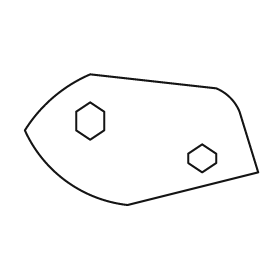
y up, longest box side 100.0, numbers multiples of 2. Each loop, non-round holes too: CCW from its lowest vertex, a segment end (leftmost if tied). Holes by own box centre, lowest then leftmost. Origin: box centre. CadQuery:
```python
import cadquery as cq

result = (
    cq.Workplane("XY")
    .moveTo(-6.0, -28.0)
    .lineTo(50.0, -14.0)
    .lineTo(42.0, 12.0)
    .threePointArc((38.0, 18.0), (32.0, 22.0))
    .lineTo(-22.0, 28.0)
    .threePointArc((-38.0, 18.0), (-50.0, 4.0))
    .threePointArc((-32.0, -18.0), (-6.0, -28.0))
    .close()
    .moveTo(26.0, -14.0)
    .lineTo(32.0, -10.0)
    .lineTo(32.0, -6.0)
    .lineTo(26.0, -2.0)
    .lineTo(20.0, -6.0)
    .lineTo(20.0, -10.0)
    .close()
    .moveTo(-22.0, 0.0)
    .lineTo(-16.0, 4.0)
    .lineTo(-16.0, 12.0)
    .lineTo(-22.0, 16.0)
    .lineTo(-28.0, 12.0)
    .lineTo(-28.0, 4.0)
    .close()
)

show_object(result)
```